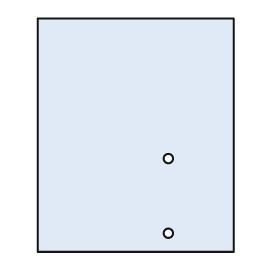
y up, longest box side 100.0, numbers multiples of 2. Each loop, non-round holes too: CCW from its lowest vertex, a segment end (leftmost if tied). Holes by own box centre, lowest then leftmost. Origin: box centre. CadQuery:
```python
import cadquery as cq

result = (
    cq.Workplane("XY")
    .moveTo(-42.0, -50.0)
    .lineTo(42.0, -50.0)
    .lineTo(42.0, 50.0)
    .lineTo(-42.0, 50.0)
    .close()
    .moveTo(14.0, -42.0)
    .circle(2.0)
    .moveTo(14.0, -10.0)
    .circle(2.0)
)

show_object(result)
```